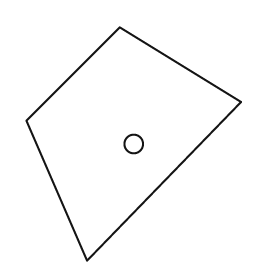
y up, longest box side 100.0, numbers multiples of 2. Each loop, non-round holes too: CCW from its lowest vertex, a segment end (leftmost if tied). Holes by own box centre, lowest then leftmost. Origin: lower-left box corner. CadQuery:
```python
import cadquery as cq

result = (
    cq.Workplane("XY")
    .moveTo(26.0, 0.0)
    .lineTo(92.0, 68.0)
    .lineTo(40.0, 100.0)
    .lineTo(0.0, 60.0)
    .close()
    .moveTo(46.0, 50.0)
    .circle(4.0)
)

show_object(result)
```